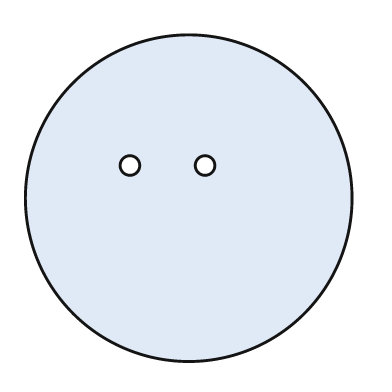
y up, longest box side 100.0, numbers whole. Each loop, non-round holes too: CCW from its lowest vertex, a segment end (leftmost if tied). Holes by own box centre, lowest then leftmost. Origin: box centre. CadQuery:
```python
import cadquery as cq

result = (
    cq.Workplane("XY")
    .moveTo(0.0, 0.0)
    .circle(50.0)
    .moveTo(-18.0, 10.0)
    .circle(3.0)
    .moveTo(5.0, 10.0)
    .circle(3.0)
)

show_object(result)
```